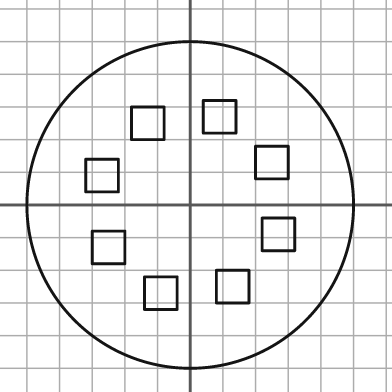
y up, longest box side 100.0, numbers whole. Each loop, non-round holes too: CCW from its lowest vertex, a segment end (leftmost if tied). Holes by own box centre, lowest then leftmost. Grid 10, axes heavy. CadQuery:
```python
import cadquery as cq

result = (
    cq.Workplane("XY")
    .moveTo(0.0, 0.0)
    .circle(50.0)
    .moveTo(-14.0, -32.0)
    .lineTo(-4.0, -32.0)
    .lineTo(-4.0, -22.0)
    .lineTo(-14.0, -22.0)
    .close()
    .moveTo(8.0, -30.0)
    .lineTo(18.0, -30.0)
    .lineTo(18.0, -20.0)
    .lineTo(8.0, -20.0)
    .close()
    .moveTo(-30.0, -18.0)
    .lineTo(-20.0, -18.0)
    .lineTo(-20.0, -8.0)
    .lineTo(-30.0, -8.0)
    .close()
    .moveTo(22.0, -14.0)
    .lineTo(32.0, -14.0)
    .lineTo(32.0, -4.0)
    .lineTo(22.0, -4.0)
    .close()
    .moveTo(-32.0, 4.0)
    .lineTo(-22.0, 4.0)
    .lineTo(-22.0, 14.0)
    .lineTo(-32.0, 14.0)
    .close()
    .moveTo(20.0, 8.0)
    .lineTo(30.0, 8.0)
    .lineTo(30.0, 18.0)
    .lineTo(20.0, 18.0)
    .close()
    .moveTo(-18.0, 20.0)
    .lineTo(-8.0, 20.0)
    .lineTo(-8.0, 30.0)
    .lineTo(-18.0, 30.0)
    .close()
    .moveTo(4.0, 22.0)
    .lineTo(14.0, 22.0)
    .lineTo(14.0, 32.0)
    .lineTo(4.0, 32.0)
    .close()
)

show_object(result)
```